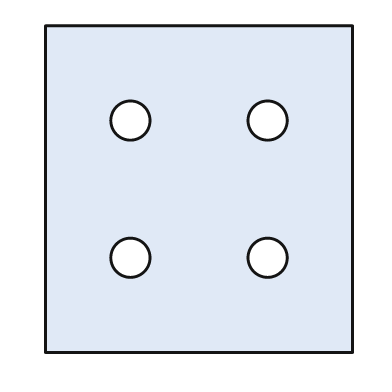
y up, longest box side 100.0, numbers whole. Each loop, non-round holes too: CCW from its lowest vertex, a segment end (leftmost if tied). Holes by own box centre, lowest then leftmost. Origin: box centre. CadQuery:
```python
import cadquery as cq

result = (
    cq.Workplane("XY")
    .moveTo(-47.0, -50.0)
    .lineTo(47.0, -50.0)
    .lineTo(47.0, 50.0)
    .lineTo(-47.0, 50.0)
    .close()
    .moveTo(-21.0, -21.0)
    .circle(6.0)
    .moveTo(21.0, -21.0)
    .circle(6.0)
    .moveTo(-21.0, 21.0)
    .circle(6.0)
    .moveTo(21.0, 21.0)
    .circle(6.0)
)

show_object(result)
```